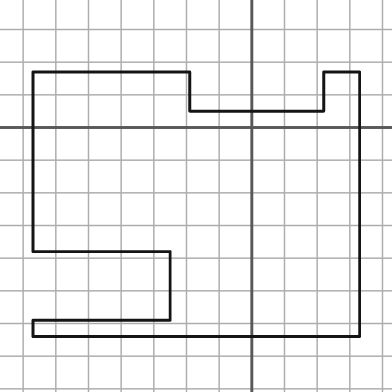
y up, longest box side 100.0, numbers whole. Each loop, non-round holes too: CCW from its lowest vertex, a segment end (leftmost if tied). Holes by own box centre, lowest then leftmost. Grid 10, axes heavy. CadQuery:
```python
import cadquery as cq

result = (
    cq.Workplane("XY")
    .moveTo(-67.0, -64.0)
    .lineTo(33.0, -64.0)
    .lineTo(33.0, 17.0)
    .lineTo(22.0, 17.0)
    .lineTo(22.0, 5.0)
    .lineTo(-19.0, 5.0)
    .lineTo(-19.0, 17.0)
    .lineTo(-67.0, 17.0)
    .lineTo(-67.0, -38.0)
    .lineTo(-25.0, -38.0)
    .lineTo(-25.0, -59.0)
    .lineTo(-67.0, -59.0)
    .close()
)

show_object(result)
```